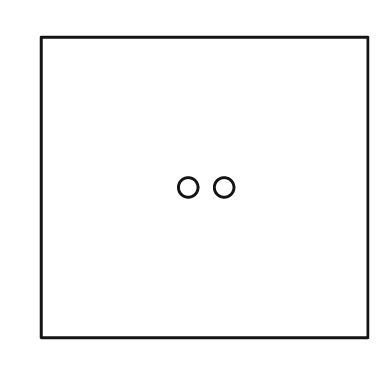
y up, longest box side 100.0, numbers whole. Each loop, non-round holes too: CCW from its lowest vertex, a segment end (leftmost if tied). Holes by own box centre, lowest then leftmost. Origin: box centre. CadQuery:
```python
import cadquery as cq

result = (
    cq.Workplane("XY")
    .moveTo(-50.0, -46.0)
    .lineTo(50.0, -46.0)
    .lineTo(50.0, 46.0)
    .lineTo(-50.0, 46.0)
    .close()
    .moveTo(-5.0, 0.0)
    .circle(3.0)
    .moveTo(6.0, 0.0)
    .circle(3.0)
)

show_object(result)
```